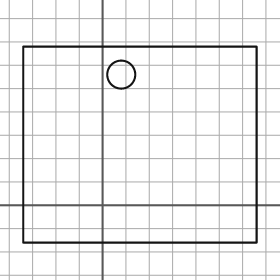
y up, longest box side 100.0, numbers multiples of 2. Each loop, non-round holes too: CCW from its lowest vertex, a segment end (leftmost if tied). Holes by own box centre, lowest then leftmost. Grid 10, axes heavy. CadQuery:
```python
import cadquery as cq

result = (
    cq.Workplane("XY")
    .moveTo(-34.0, -16.0)
    .lineTo(66.0, -16.0)
    .lineTo(66.0, 68.0)
    .lineTo(-34.0, 68.0)
    .close()
    .moveTo(8.0, 56.0)
    .circle(6.0)
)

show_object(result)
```